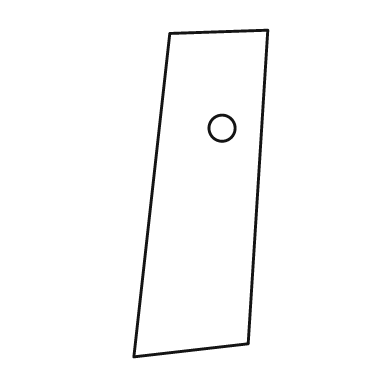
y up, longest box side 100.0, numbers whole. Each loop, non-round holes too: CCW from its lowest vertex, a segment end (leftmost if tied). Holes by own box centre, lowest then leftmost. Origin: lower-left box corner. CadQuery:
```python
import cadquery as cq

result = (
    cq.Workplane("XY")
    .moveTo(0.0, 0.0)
    .lineTo(35.0, 4.0)
    .lineTo(41.0, 100.0)
    .lineTo(11.0, 99.0)
    .close()
    .moveTo(27.0, 70.0)
    .circle(4.0)
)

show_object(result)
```